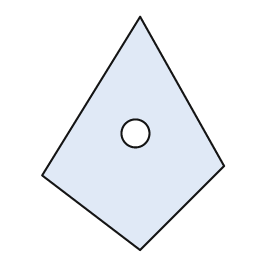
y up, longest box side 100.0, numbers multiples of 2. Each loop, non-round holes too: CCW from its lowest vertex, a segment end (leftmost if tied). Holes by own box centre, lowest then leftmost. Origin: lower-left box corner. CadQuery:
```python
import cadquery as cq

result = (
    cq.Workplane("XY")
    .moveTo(42.0, 0.0)
    .lineTo(78.0, 36.0)
    .lineTo(42.0, 100.0)
    .lineTo(0.0, 32.0)
    .close()
    .moveTo(40.0, 50.0)
    .circle(6.0)
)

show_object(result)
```